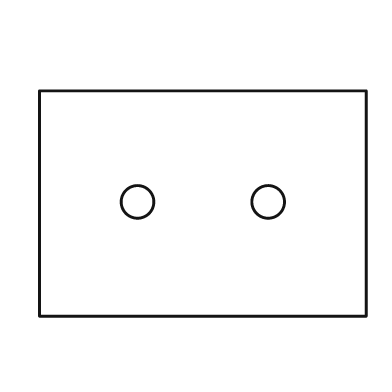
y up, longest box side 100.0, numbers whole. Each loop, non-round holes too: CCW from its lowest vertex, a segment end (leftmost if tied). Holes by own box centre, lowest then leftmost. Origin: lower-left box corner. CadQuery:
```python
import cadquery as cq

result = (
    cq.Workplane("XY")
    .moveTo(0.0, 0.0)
    .lineTo(100.0, 0.0)
    .lineTo(100.0, 69.0)
    .lineTo(0.0, 69.0)
    .close()
    .moveTo(30.0, 35.0)
    .circle(5.0)
    .moveTo(70.0, 35.0)
    .circle(5.0)
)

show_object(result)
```